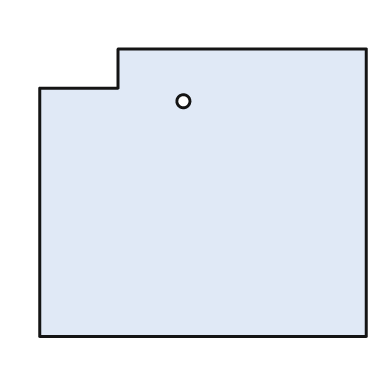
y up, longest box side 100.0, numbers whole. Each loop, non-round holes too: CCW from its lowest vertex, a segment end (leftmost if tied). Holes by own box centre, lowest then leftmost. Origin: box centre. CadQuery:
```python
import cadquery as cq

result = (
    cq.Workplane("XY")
    .moveTo(-50.0, -44.0)
    .lineTo(50.0, -44.0)
    .lineTo(50.0, 44.0)
    .lineTo(-26.0, 44.0)
    .lineTo(-26.0, 32.0)
    .lineTo(-50.0, 32.0)
    .close()
    .moveTo(-6.0, 28.0)
    .circle(2.0)
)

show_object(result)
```